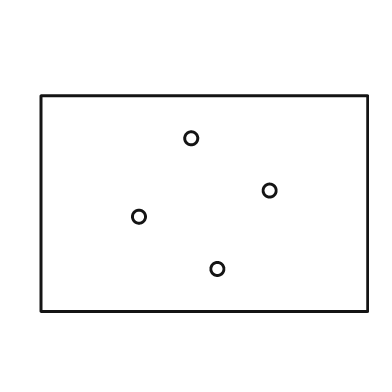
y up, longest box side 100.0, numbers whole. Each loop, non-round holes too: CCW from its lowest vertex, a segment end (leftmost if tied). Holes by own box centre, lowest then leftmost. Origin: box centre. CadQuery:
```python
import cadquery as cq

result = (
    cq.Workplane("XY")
    .moveTo(-50.0, -33.0)
    .lineTo(50.0, -33.0)
    .lineTo(50.0, 33.0)
    .lineTo(-50.0, 33.0)
    .close()
    .moveTo(4.0, -20.0)
    .circle(2.0)
    .moveTo(-20.0, -4.0)
    .circle(2.0)
    .moveTo(20.0, 4.0)
    .circle(2.0)
    .moveTo(-4.0, 20.0)
    .circle(2.0)
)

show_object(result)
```